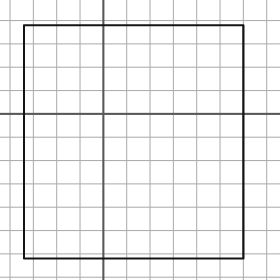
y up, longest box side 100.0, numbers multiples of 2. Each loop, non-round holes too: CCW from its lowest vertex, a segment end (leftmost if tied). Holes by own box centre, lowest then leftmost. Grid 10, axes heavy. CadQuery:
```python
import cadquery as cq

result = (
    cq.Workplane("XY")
    .moveTo(-34.0, -62.0)
    .lineTo(60.0, -62.0)
    .lineTo(60.0, 38.0)
    .lineTo(-34.0, 38.0)
    .close()
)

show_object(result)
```